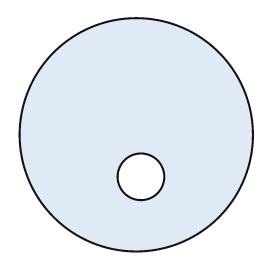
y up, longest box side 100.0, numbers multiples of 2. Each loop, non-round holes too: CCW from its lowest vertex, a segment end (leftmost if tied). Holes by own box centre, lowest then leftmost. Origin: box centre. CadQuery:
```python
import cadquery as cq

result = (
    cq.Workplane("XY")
    .moveTo(0.0, 0.0)
    .circle(50.0)
    .moveTo(2.0, -18.0)
    .circle(10.0)
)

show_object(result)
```